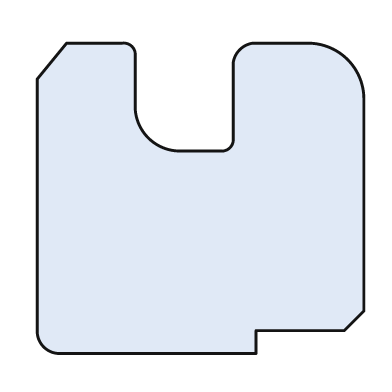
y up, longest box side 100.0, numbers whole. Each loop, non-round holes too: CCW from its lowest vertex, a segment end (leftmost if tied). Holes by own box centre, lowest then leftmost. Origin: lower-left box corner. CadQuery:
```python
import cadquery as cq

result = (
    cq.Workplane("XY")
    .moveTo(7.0, 0.0)
    .lineTo(67.0, 0.0)
    .lineTo(67.0, 7.0)
    .lineTo(94.0, 7.0)
    .lineTo(100.0, 13.0)
    .lineTo(100.0, 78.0)
    .threePointArc((95.0, 90.0), (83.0, 95.0))
    .lineTo(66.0, 95.0)
    .threePointArc((62.0, 93.0), (60.0, 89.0))
    .lineTo(60.0, 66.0)
    .threePointArc((59.0, 63.0), (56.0, 62.0))
    .lineTo(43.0, 62.0)
    .threePointArc((34.0, 66.0), (30.0, 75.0))
    .lineTo(30.0, 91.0)
    .threePointArc((29.0, 94.0), (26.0, 95.0))
    .lineTo(9.0, 95.0)
    .lineTo(0.0, 84.0)
    .lineTo(0.0, 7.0)
    .threePointArc((2.0, 2.0), (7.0, 0.0))
    .close()
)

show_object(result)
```